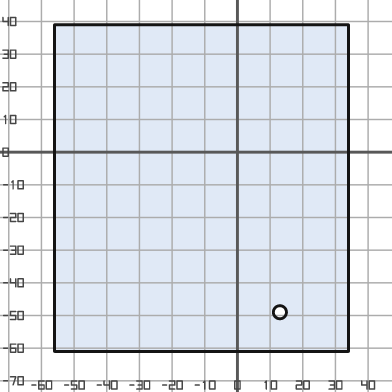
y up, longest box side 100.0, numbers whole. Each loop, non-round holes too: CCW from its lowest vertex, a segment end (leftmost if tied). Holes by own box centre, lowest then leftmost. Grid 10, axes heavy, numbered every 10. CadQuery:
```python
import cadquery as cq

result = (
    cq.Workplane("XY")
    .moveTo(-56.0, -61.0)
    .lineTo(34.0, -61.0)
    .lineTo(34.0, 39.0)
    .lineTo(-56.0, 39.0)
    .close()
    .moveTo(13.0, -49.0)
    .circle(2.0)
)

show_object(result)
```